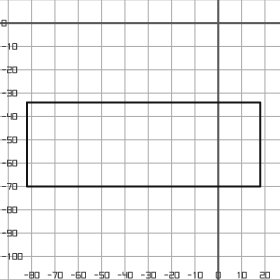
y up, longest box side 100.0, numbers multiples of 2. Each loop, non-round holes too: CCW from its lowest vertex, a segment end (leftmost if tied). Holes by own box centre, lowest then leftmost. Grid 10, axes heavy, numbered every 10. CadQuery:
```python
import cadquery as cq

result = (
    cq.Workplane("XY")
    .moveTo(-82.0, -70.0)
    .lineTo(18.0, -70.0)
    .lineTo(18.0, -34.0)
    .lineTo(-82.0, -34.0)
    .close()
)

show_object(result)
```